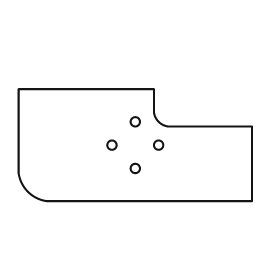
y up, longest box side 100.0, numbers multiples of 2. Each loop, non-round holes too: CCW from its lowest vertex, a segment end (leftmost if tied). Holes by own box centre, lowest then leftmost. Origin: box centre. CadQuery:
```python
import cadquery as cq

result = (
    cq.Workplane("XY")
    .moveTo(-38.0, -24.0)
    .lineTo(50.0, -24.0)
    .lineTo(50.0, 8.0)
    .lineTo(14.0, 8.0)
    .threePointArc((10.0, 10.0), (8.0, 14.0))
    .lineTo(8.0, 24.0)
    .lineTo(-50.0, 24.0)
    .lineTo(-50.0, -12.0)
    .threePointArc((-46.0, -20.0), (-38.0, -24.0))
    .close()
    .moveTo(0.0, -10.0)
    .circle(2.0)
    .moveTo(-10.0, 0.0)
    .circle(2.0)
    .moveTo(10.0, 0.0)
    .circle(2.0)
    .moveTo(0.0, 10.0)
    .circle(2.0)
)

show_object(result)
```